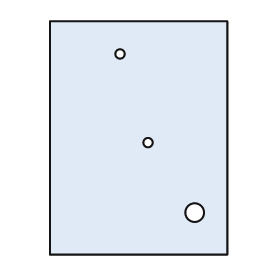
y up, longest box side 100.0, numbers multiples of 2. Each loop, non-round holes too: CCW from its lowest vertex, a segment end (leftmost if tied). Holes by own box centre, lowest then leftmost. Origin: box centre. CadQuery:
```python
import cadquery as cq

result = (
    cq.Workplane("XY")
    .moveTo(-38.0, -50.0)
    .lineTo(38.0, -50.0)
    .lineTo(38.0, 50.0)
    .lineTo(-38.0, 50.0)
    .close()
    .moveTo(24.0, -32.0)
    .circle(4.0)
    .moveTo(4.0, -2.0)
    .circle(2.0)
    .moveTo(-8.0, 36.0)
    .circle(2.0)
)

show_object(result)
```